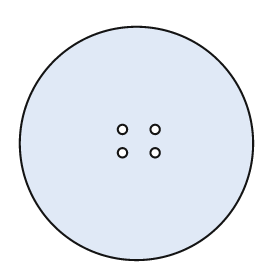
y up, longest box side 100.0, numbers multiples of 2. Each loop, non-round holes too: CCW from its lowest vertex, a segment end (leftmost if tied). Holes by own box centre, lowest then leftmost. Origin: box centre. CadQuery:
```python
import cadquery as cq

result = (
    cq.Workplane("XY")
    .moveTo(0.0, 0.0)
    .circle(50.0)
    .moveTo(-6.0, -4.0)
    .circle(2.0)
    .moveTo(8.0, -4.0)
    .circle(2.0)
    .moveTo(-6.0, 6.0)
    .circle(2.0)
    .moveTo(8.0, 6.0)
    .circle(2.0)
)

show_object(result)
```